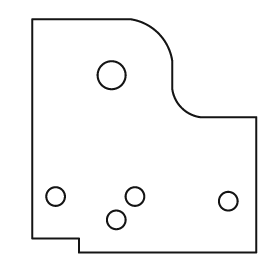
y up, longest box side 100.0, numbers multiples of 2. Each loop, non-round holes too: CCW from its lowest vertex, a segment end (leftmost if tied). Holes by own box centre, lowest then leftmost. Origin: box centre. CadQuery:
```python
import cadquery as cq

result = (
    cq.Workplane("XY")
    .moveTo(-28.0, -50.0)
    .lineTo(48.0, -50.0)
    .lineTo(48.0, 8.0)
    .lineTo(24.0, 8.0)
    .threePointArc((16.0, 12.0), (12.0, 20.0))
    .lineTo(12.0, 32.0)
    .threePointArc((6.0, 44.0), (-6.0, 50.0))
    .lineTo(-48.0, 50.0)
    .lineTo(-48.0, -44.0)
    .lineTo(-28.0, -44.0)
    .close()
    .moveTo(-12.0, -36.0)
    .circle(4.0)
    .moveTo(36.0, -28.0)
    .circle(4.0)
    .moveTo(-38.0, -26.0)
    .circle(4.0)
    .moveTo(-4.0, -26.0)
    .circle(4.0)
    .moveTo(-14.0, 26.0)
    .circle(6.0)
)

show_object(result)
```